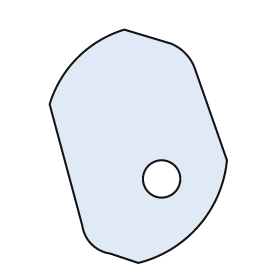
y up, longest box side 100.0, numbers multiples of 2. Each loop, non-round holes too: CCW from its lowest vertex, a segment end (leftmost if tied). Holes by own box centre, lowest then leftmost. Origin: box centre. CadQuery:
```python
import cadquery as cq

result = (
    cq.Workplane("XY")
    .moveTo(0.0, -50.0)
    .threePointArc((26.0, -34.0), (38.0, -6.0))
    .lineTo(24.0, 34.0)
    .threePointArc((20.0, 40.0), (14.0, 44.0))
    .lineTo(-6.0, 50.0)
    .threePointArc((-26.0, 38.0), (-38.0, 18.0))
    .lineTo(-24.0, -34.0)
    .threePointArc((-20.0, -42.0), (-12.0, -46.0))
    .close()
    .moveTo(10.0, -14.0)
    .circle(8.0)
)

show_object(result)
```